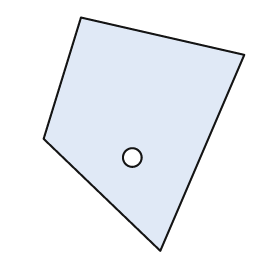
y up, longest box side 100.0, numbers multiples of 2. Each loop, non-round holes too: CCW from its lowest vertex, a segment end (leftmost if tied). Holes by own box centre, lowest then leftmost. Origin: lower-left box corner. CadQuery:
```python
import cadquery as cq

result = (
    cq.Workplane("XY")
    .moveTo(50.0, 0.0)
    .lineTo(86.0, 84.0)
    .lineTo(16.0, 100.0)
    .lineTo(0.0, 48.0)
    .close()
    .moveTo(38.0, 40.0)
    .circle(4.0)
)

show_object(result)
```